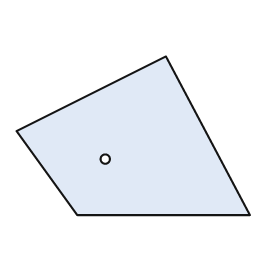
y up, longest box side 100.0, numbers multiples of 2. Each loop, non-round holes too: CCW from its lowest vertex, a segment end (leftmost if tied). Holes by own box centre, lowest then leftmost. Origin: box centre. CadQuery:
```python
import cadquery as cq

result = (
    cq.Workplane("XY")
    .moveTo(-24.0, -34.0)
    .lineTo(50.0, -34.0)
    .lineTo(14.0, 34.0)
    .lineTo(-50.0, 2.0)
    .close()
    .moveTo(-12.0, -10.0)
    .circle(2.0)
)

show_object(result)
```